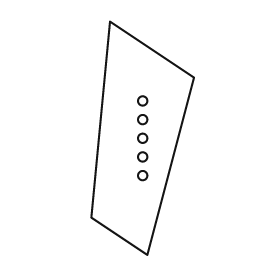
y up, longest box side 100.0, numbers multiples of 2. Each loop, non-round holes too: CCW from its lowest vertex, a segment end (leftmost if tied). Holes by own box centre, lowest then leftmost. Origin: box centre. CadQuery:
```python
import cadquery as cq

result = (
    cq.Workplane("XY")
    .moveTo(2.0, -50.0)
    .lineTo(22.0, 26.0)
    .lineTo(-14.0, 50.0)
    .lineTo(-22.0, -34.0)
    .close()
    .moveTo(0.0, -16.0)
    .circle(2.0)
    .moveTo(0.0, -8.0)
    .circle(2.0)
    .moveTo(0.0, 0.0)
    .circle(2.0)
    .moveTo(0.0, 8.0)
    .circle(2.0)
    .moveTo(0.0, 16.0)
    .circle(2.0)
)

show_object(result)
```